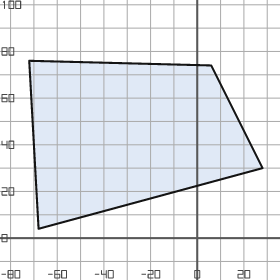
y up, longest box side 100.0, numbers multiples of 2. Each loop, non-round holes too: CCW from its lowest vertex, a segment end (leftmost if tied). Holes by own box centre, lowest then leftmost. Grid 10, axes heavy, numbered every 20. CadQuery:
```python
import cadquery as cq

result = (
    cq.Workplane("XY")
    .moveTo(-68.0, 4.0)
    .lineTo(28.0, 30.0)
    .lineTo(6.0, 74.0)
    .lineTo(-72.0, 76.0)
    .close()
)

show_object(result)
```